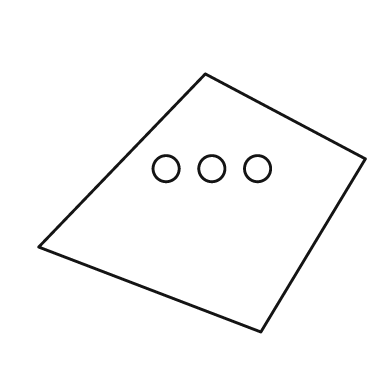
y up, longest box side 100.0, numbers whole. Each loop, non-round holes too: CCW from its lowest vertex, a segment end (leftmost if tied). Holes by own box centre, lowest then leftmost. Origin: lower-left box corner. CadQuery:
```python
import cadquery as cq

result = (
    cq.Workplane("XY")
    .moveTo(68.0, 0.0)
    .lineTo(100.0, 53.0)
    .lineTo(51.0, 79.0)
    .lineTo(0.0, 26.0)
    .close()
    .moveTo(39.0, 50.0)
    .circle(4.0)
    .moveTo(53.0, 50.0)
    .circle(4.0)
    .moveTo(67.0, 50.0)
    .circle(4.0)
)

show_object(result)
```